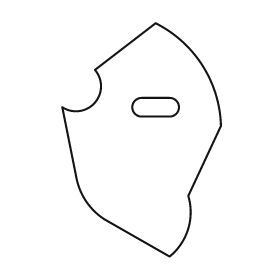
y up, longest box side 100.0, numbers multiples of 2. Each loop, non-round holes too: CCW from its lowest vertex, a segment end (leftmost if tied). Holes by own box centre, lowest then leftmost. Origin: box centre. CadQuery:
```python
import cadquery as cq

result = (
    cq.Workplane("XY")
    .moveTo(12.0, -50.0)
    .threePointArc((20.0, -38.0), (20.0, -24.0))
    .lineTo(34.0, 6.0)
    .threePointArc((26.0, 32.0), (6.0, 50.0))
    .lineTo(-20.0, 30.0)
    .threePointArc((-20.0, 16.0), (-34.0, 14.0))
    .lineTo(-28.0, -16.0)
    .threePointArc((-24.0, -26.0), (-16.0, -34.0))
    .close()
    .moveTo(0.0, 10.0)
    .lineTo(12.0, 10.0)
    .threePointArc((16.0, 14.0), (12.0, 18.0))
    .lineTo(0.0, 18.0)
    .threePointArc((-4.0, 14.0), (0.0, 10.0))
    .close()
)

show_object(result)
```